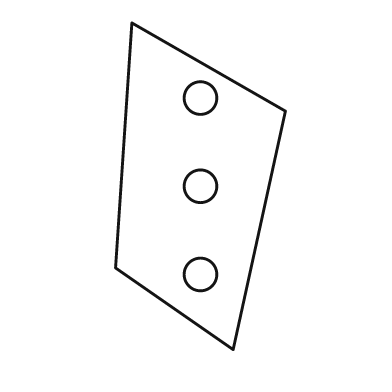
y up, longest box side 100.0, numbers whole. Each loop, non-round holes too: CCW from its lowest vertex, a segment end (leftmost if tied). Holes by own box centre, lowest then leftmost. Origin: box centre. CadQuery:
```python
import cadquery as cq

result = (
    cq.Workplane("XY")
    .moveTo(10.0, -50.0)
    .lineTo(26.0, 23.0)
    .lineTo(-21.0, 50.0)
    .lineTo(-26.0, -25.0)
    .close()
    .moveTo(0.0, -27.0)
    .circle(5.0)
    .moveTo(0.0, 0.0)
    .circle(5.0)
    .moveTo(0.0, 27.0)
    .circle(5.0)
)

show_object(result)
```